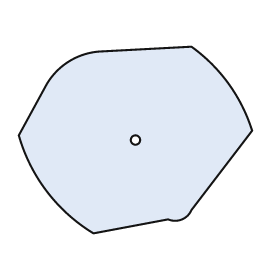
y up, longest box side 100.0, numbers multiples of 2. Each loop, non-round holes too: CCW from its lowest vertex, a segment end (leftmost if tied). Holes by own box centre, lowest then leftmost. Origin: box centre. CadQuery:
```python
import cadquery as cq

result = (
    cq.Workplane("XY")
    .moveTo(-18.0, -40.0)
    .lineTo(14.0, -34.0)
    .threePointArc((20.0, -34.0), (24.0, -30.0))
    .lineTo(50.0, 4.0)
    .threePointArc((40.0, 24.0), (24.0, 40.0))
    .lineTo(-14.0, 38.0)
    .threePointArc((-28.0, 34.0), (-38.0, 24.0))
    .lineTo(-50.0, 2.0)
    .threePointArc((-38.0, -22.0), (-18.0, -40.0))
    .close()
    .moveTo(0.0, 0.0)
    .circle(2.0)
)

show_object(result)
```